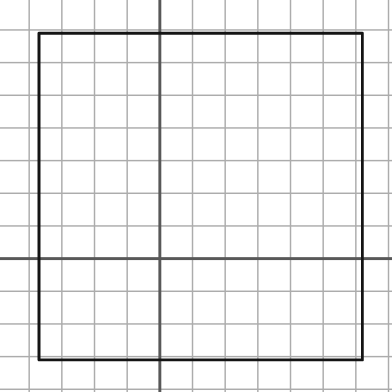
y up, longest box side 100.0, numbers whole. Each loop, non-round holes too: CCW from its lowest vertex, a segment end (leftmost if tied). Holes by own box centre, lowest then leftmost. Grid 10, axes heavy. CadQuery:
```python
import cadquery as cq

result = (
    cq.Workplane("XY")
    .moveTo(-37.0, -31.0)
    .lineTo(62.0, -31.0)
    .lineTo(62.0, 69.0)
    .lineTo(-37.0, 69.0)
    .close()
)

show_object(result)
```